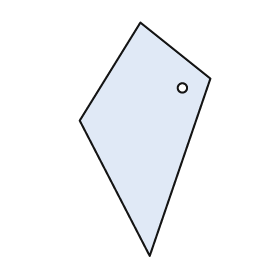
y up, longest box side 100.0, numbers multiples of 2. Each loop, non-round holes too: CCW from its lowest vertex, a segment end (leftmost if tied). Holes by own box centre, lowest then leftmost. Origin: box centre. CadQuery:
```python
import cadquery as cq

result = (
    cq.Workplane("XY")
    .moveTo(2.0, -50.0)
    .lineTo(28.0, 26.0)
    .lineTo(-2.0, 50.0)
    .lineTo(-28.0, 8.0)
    .close()
    .moveTo(16.0, 22.0)
    .circle(2.0)
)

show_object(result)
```